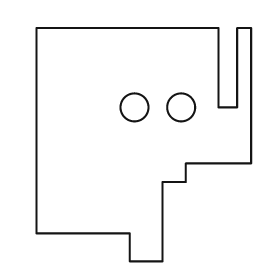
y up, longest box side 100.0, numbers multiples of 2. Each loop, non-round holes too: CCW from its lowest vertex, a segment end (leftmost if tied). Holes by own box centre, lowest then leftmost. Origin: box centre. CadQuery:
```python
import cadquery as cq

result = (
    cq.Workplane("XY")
    .moveTo(-6.0, -50.0)
    .lineTo(8.0, -50.0)
    .lineTo(8.0, -16.0)
    .lineTo(18.0, -16.0)
    .lineTo(18.0, -8.0)
    .lineTo(46.0, -8.0)
    .lineTo(46.0, 50.0)
    .lineTo(40.0, 50.0)
    .lineTo(40.0, 16.0)
    .lineTo(32.0, 16.0)
    .lineTo(32.0, 50.0)
    .lineTo(-46.0, 50.0)
    .lineTo(-46.0, -38.0)
    .lineTo(-6.0, -38.0)
    .close()
    .moveTo(-4.0, 16.0)
    .circle(6.0)
    .moveTo(16.0, 16.0)
    .circle(6.0)
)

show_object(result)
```